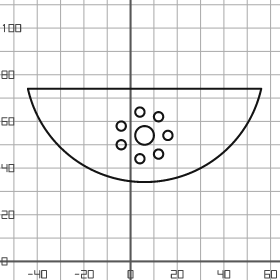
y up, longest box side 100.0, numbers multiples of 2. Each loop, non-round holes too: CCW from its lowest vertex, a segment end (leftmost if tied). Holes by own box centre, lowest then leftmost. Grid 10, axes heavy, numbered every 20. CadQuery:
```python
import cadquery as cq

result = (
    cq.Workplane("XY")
    .moveTo(-44.0, 74.0)
    .threePointArc((6.0, 34.0), (56.0, 74.0))
    .close()
    .moveTo(4.0, 44.0)
    .circle(2.0)
    .moveTo(12.0, 46.0)
    .circle(2.0)
    .moveTo(-4.0, 50.0)
    .circle(2.0)
    .moveTo(6.0, 54.0)
    .circle(4.0)
    .moveTo(16.0, 54.0)
    .circle(2.0)
    .moveTo(-4.0, 58.0)
    .circle(2.0)
    .moveTo(12.0, 62.0)
    .circle(2.0)
    .moveTo(4.0, 64.0)
    .circle(2.0)
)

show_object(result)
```